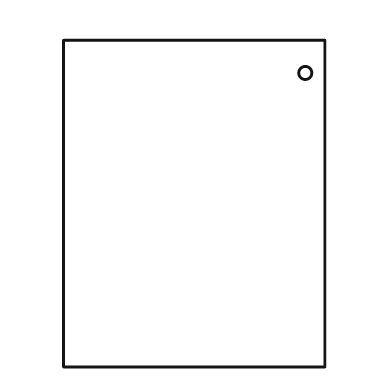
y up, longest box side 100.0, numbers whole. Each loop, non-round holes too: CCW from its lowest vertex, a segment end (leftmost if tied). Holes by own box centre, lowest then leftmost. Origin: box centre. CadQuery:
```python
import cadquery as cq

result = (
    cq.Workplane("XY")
    .moveTo(-40.0, -50.0)
    .lineTo(40.0, -50.0)
    .lineTo(40.0, 50.0)
    .lineTo(-40.0, 50.0)
    .close()
    .moveTo(34.0, 40.0)
    .circle(2.0)
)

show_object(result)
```